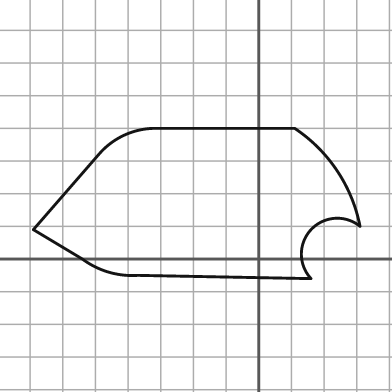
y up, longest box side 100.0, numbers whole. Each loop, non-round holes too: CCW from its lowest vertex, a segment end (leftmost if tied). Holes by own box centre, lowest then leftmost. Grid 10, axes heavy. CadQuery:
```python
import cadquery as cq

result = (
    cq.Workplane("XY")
    .moveTo(16.0, -6.0)
    .threePointArc((16.0, 9.0), (31.0, 10.0))
    .threePointArc((24.0, 27.0), (11.0, 40.0))
    .lineTo(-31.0, 40.0)
    .threePointArc((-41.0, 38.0), (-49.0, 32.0))
    .lineTo(-69.0, 9.0)
    .lineTo(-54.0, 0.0)
    .threePointArc((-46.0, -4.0), (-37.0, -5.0))
    .close()
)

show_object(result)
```